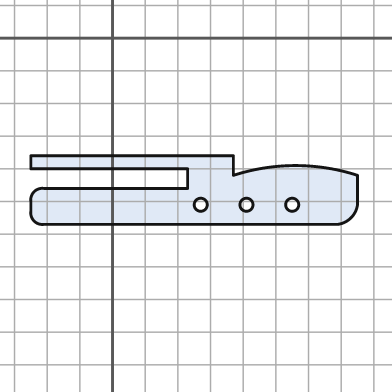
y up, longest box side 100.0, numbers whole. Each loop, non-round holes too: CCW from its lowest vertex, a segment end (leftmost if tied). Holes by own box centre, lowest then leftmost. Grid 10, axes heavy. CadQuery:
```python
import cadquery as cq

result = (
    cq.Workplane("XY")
    .moveTo(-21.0, -57.0)
    .lineTo(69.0, -57.0)
    .threePointArc((73.0, -55.0), (75.0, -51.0))
    .lineTo(75.0, -42.0)
    .threePointArc((56.0, -39.0), (37.0, -42.0))
    .lineTo(37.0, -36.0)
    .lineTo(-25.0, -36.0)
    .lineTo(-25.0, -40.0)
    .lineTo(23.0, -40.0)
    .lineTo(23.0, -46.0)
    .lineTo(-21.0, -46.0)
    .threePointArc((-24.0, -47.0), (-25.0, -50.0))
    .lineTo(-25.0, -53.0)
    .threePointArc((-24.0, -56.0), (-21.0, -57.0))
    .close()
    .moveTo(27.0, -51.0)
    .circle(2.0)
    .moveTo(41.0, -51.0)
    .circle(2.0)
    .moveTo(55.0, -51.0)
    .circle(2.0)
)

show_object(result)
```